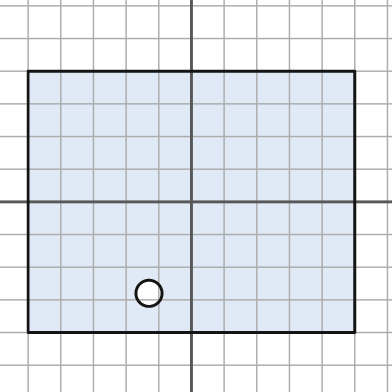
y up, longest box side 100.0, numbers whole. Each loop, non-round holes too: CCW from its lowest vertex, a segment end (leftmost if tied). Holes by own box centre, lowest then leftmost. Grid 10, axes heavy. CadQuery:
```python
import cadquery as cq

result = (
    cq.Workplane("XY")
    .moveTo(-50.0, -40.0)
    .lineTo(50.0, -40.0)
    .lineTo(50.0, 40.0)
    .lineTo(-50.0, 40.0)
    .close()
    .moveTo(-13.0, -28.0)
    .circle(4.0)
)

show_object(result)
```